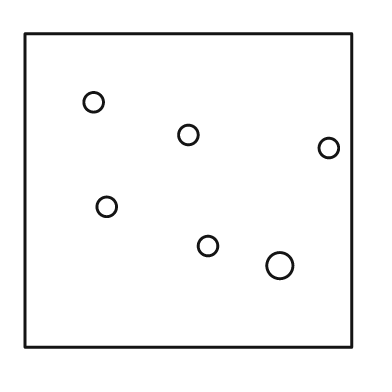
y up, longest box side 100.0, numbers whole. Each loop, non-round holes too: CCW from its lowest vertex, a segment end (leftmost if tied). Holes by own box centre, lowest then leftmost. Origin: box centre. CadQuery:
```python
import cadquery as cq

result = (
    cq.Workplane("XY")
    .moveTo(-50.0, -48.0)
    .lineTo(50.0, -48.0)
    .lineTo(50.0, 48.0)
    .lineTo(-50.0, 48.0)
    .close()
    .moveTo(28.0, -23.0)
    .circle(4.0)
    .moveTo(6.0, -17.0)
    .circle(3.0)
    .moveTo(-25.0, -5.0)
    .circle(3.0)
    .moveTo(43.0, 13.0)
    .circle(3.0)
    .moveTo(0.0, 17.0)
    .circle(3.0)
    .moveTo(-29.0, 27.0)
    .circle(3.0)
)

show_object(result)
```